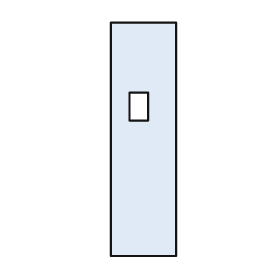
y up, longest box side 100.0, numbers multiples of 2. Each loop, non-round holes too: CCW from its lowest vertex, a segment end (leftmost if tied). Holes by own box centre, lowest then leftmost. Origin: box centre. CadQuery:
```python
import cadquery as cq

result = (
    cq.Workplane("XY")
    .moveTo(-14.0, -50.0)
    .lineTo(14.0, -50.0)
    .lineTo(14.0, 50.0)
    .lineTo(-14.0, 50.0)
    .close()
    .moveTo(-6.0, 8.0)
    .lineTo(2.0, 8.0)
    .lineTo(2.0, 20.0)
    .lineTo(-6.0, 20.0)
    .close()
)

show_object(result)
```